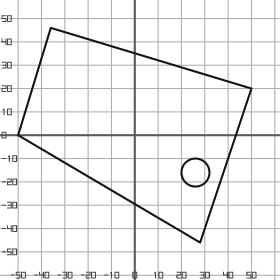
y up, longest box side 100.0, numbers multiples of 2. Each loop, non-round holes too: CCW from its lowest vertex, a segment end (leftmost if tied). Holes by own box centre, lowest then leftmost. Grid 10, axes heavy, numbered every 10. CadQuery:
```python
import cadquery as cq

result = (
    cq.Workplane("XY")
    .moveTo(28.0, -46.0)
    .lineTo(50.0, 20.0)
    .lineTo(-36.0, 46.0)
    .lineTo(-50.0, 0.0)
    .close()
    .moveTo(26.0, -16.0)
    .circle(6.0)
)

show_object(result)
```